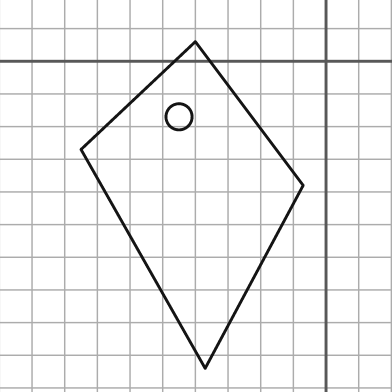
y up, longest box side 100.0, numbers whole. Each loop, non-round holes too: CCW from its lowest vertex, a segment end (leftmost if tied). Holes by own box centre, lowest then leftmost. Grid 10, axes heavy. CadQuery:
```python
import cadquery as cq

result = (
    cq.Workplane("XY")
    .moveTo(-37.0, -94.0)
    .lineTo(-7.0, -38.0)
    .lineTo(-40.0, 6.0)
    .lineTo(-75.0, -27.0)
    .close()
    .moveTo(-45.0, -17.0)
    .circle(4.0)
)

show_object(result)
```